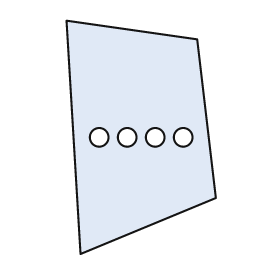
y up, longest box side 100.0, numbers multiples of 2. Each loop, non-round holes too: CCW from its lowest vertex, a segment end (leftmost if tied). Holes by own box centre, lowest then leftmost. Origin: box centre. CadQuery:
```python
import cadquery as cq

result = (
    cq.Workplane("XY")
    .moveTo(-26.0, -50.0)
    .lineTo(32.0, -26.0)
    .lineTo(24.0, 42.0)
    .lineTo(-32.0, 50.0)
    .close()
    .moveTo(-18.0, 0.0)
    .circle(4.0)
    .moveTo(-6.0, 0.0)
    .circle(4.0)
    .moveTo(6.0, 0.0)
    .circle(4.0)
    .moveTo(18.0, 0.0)
    .circle(4.0)
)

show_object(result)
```